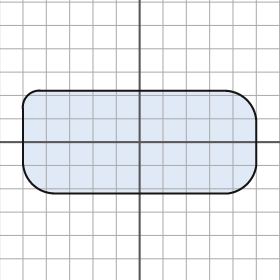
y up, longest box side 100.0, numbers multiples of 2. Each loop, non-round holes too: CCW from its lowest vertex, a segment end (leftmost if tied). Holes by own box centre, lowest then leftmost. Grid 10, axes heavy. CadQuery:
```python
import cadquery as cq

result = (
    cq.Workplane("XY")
    .moveTo(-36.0, -22.0)
    .lineTo(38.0, -22.0)
    .threePointArc((46.0, -18.0), (50.0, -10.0))
    .lineTo(50.0, 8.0)
    .threePointArc((46.0, 18.0), (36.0, 22.0))
    .lineTo(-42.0, 22.0)
    .threePointArc((-48.0, 20.0), (-50.0, 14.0))
    .lineTo(-50.0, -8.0)
    .threePointArc((-46.0, -18.0), (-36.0, -22.0))
    .close()
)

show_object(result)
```